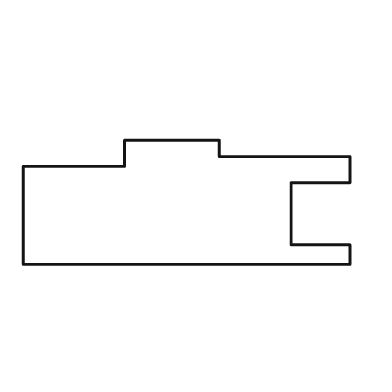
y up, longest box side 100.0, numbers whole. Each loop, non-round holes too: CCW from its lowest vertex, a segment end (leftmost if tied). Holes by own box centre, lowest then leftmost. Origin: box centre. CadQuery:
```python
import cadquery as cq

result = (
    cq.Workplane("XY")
    .moveTo(-50.0, -19.0)
    .lineTo(50.0, -19.0)
    .lineTo(50.0, -13.0)
    .lineTo(32.0, -13.0)
    .lineTo(32.0, 6.0)
    .lineTo(50.0, 6.0)
    .lineTo(50.0, 14.0)
    .lineTo(10.0, 14.0)
    .lineTo(10.0, 19.0)
    .lineTo(-19.0, 19.0)
    .lineTo(-19.0, 11.0)
    .lineTo(-50.0, 11.0)
    .close()
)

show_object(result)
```